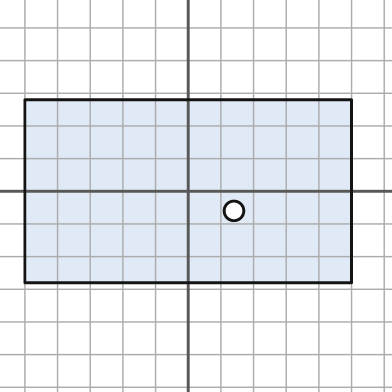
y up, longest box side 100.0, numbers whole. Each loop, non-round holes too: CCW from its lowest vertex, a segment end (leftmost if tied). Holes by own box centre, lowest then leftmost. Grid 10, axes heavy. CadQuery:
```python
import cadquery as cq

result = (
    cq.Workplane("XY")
    .moveTo(-50.0, -28.0)
    .lineTo(50.0, -28.0)
    .lineTo(50.0, 28.0)
    .lineTo(-50.0, 28.0)
    .close()
    .moveTo(14.0, -6.0)
    .circle(3.0)
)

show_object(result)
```